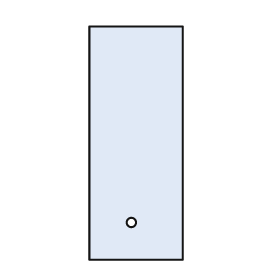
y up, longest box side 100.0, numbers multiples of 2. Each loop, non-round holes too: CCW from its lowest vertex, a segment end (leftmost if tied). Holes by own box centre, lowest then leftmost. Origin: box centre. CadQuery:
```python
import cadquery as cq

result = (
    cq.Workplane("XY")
    .moveTo(-20.0, -50.0)
    .lineTo(20.0, -50.0)
    .lineTo(20.0, 50.0)
    .lineTo(-20.0, 50.0)
    .close()
    .moveTo(-2.0, -34.0)
    .circle(2.0)
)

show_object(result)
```